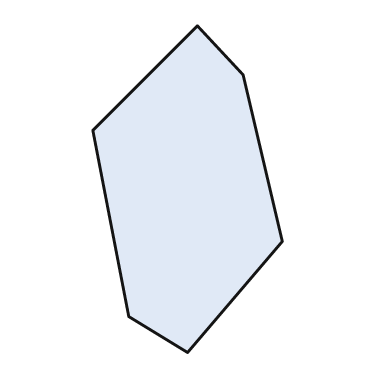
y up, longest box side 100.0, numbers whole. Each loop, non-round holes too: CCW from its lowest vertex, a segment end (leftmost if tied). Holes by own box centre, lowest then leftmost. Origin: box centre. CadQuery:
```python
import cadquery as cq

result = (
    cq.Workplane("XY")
    .moveTo(0.0, -50.0)
    .lineTo(29.0, -16.0)
    .lineTo(17.0, 35.0)
    .lineTo(3.0, 50.0)
    .lineTo(-29.0, 18.0)
    .lineTo(-18.0, -39.0)
    .close()
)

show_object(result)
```